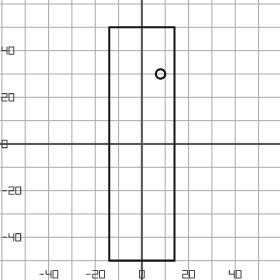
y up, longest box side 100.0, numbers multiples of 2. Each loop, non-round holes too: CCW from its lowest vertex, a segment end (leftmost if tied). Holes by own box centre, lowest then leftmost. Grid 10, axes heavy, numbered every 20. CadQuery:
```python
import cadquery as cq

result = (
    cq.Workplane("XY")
    .moveTo(-14.0, -50.0)
    .lineTo(14.0, -50.0)
    .lineTo(14.0, 50.0)
    .lineTo(-14.0, 50.0)
    .close()
    .moveTo(8.0, 30.0)
    .circle(2.0)
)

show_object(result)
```